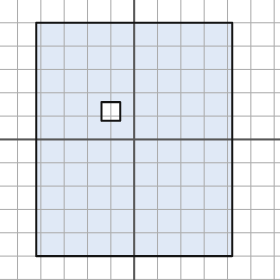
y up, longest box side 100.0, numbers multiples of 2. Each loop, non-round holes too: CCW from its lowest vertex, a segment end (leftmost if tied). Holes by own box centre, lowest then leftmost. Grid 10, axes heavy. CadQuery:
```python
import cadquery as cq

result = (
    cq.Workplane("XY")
    .moveTo(-42.0, -50.0)
    .lineTo(42.0, -50.0)
    .lineTo(42.0, 50.0)
    .lineTo(-42.0, 50.0)
    .close()
    .moveTo(-14.0, 8.0)
    .lineTo(-6.0, 8.0)
    .lineTo(-6.0, 16.0)
    .lineTo(-14.0, 16.0)
    .close()
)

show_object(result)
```